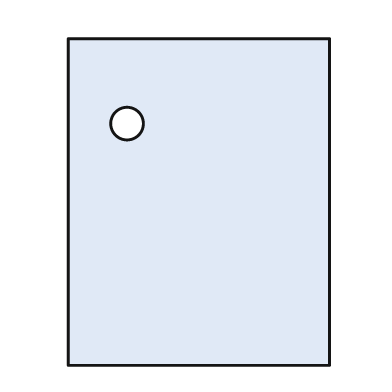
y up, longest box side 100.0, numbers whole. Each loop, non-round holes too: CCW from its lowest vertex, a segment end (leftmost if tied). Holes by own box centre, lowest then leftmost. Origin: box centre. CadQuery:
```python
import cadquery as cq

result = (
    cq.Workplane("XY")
    .moveTo(-40.0, -50.0)
    .lineTo(40.0, -50.0)
    .lineTo(40.0, 50.0)
    .lineTo(-40.0, 50.0)
    .close()
    .moveTo(-22.0, 24.0)
    .circle(5.0)
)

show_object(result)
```